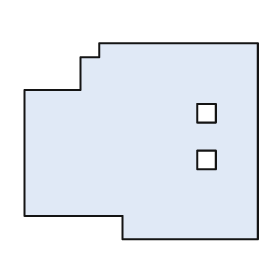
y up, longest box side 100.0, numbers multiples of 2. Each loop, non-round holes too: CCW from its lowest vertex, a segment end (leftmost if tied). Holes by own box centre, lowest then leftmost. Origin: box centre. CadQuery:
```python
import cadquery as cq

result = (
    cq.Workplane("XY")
    .moveTo(-8.0, -42.0)
    .lineTo(50.0, -42.0)
    .lineTo(50.0, 42.0)
    .lineTo(-18.0, 42.0)
    .lineTo(-18.0, 36.0)
    .lineTo(-26.0, 36.0)
    .lineTo(-26.0, 22.0)
    .lineTo(-50.0, 22.0)
    .lineTo(-50.0, -32.0)
    .lineTo(-8.0, -32.0)
    .close()
    .moveTo(24.0, -12.0)
    .lineTo(32.0, -12.0)
    .lineTo(32.0, -4.0)
    .lineTo(24.0, -4.0)
    .close()
    .moveTo(24.0, 8.0)
    .lineTo(32.0, 8.0)
    .lineTo(32.0, 16.0)
    .lineTo(24.0, 16.0)
    .close()
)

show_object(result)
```